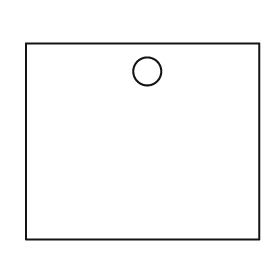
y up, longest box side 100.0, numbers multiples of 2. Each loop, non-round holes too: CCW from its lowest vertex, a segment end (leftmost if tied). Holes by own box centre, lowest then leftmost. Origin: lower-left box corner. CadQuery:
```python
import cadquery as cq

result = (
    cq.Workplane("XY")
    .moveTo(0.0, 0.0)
    .lineTo(100.0, 0.0)
    .lineTo(100.0, 84.0)
    .lineTo(0.0, 84.0)
    .close()
    .moveTo(52.0, 72.0)
    .circle(6.0)
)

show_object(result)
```